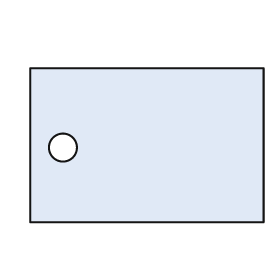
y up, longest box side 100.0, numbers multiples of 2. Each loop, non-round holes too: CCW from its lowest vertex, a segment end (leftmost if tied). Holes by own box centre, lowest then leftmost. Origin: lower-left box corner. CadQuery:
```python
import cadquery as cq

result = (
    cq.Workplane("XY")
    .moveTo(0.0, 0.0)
    .lineTo(100.0, 0.0)
    .lineTo(100.0, 66.0)
    .lineTo(0.0, 66.0)
    .close()
    .moveTo(14.0, 32.0)
    .circle(6.0)
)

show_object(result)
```